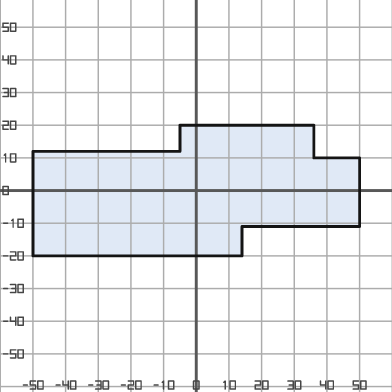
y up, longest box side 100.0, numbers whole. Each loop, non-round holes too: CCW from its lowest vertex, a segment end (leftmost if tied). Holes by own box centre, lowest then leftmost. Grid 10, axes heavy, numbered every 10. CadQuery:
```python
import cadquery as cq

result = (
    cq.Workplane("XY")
    .moveTo(-50.0, -20.0)
    .lineTo(14.0, -20.0)
    .lineTo(14.0, -11.0)
    .lineTo(50.0, -11.0)
    .lineTo(50.0, 10.0)
    .lineTo(36.0, 10.0)
    .lineTo(36.0, 20.0)
    .lineTo(-5.0, 20.0)
    .lineTo(-5.0, 12.0)
    .lineTo(-50.0, 12.0)
    .close()
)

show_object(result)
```